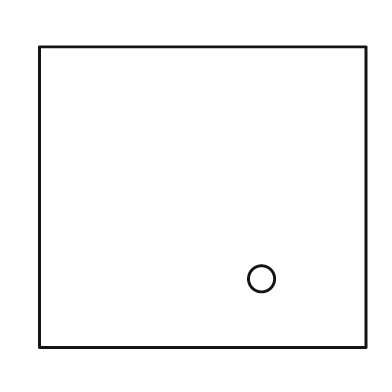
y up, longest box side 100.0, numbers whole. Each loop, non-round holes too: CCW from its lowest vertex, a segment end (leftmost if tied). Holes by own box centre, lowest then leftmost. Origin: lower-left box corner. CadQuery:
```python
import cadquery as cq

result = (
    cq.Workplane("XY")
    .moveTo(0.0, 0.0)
    .lineTo(100.0, 0.0)
    .lineTo(100.0, 92.0)
    .lineTo(0.0, 92.0)
    .close()
    .moveTo(68.0, 21.0)
    .circle(4.0)
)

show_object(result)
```